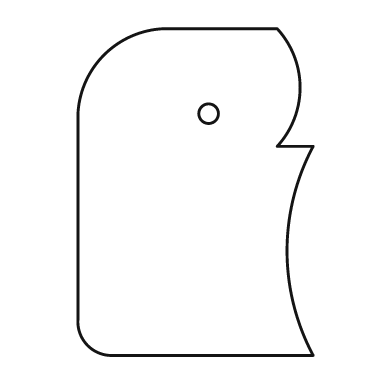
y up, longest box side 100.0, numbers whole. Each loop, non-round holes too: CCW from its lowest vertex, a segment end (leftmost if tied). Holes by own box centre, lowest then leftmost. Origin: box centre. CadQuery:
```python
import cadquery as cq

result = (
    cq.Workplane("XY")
    .moveTo(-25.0, -50.0)
    .lineTo(36.0, -50.0)
    .threePointArc((28.0, -18.0), (36.0, 14.0))
    .lineTo(25.0, 14.0)
    .threePointArc((32.0, 32.0), (25.0, 50.0))
    .lineTo(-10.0, 50.0)
    .threePointArc((-28.0, 42.0), (-36.0, 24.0))
    .lineTo(-36.0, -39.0)
    .threePointArc((-33.0, -47.0), (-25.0, -50.0))
    .close()
    .moveTo(4.0, 24.0)
    .circle(3.0)
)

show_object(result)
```